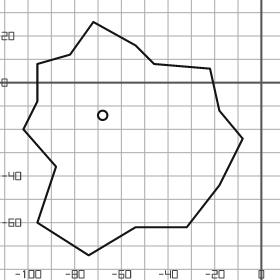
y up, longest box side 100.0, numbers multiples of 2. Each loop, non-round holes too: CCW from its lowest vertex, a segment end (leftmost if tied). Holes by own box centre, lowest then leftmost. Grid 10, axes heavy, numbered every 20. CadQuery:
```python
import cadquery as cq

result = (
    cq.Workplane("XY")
    .moveTo(-74.0, -74.0)
    .lineTo(-54.0, -62.0)
    .lineTo(-32.0, -62.0)
    .lineTo(-18.0, -44.0)
    .lineTo(-8.0, -24.0)
    .lineTo(-18.0, -12.0)
    .lineTo(-22.0, 6.0)
    .lineTo(-46.0, 8.0)
    .lineTo(-54.0, 16.0)
    .lineTo(-72.0, 26.0)
    .lineTo(-82.0, 12.0)
    .lineTo(-96.0, 8.0)
    .lineTo(-96.0, -8.0)
    .lineTo(-102.0, -20.0)
    .lineTo(-88.0, -36.0)
    .lineTo(-96.0, -60.0)
    .close()
    .moveTo(-68.0, -14.0)
    .circle(2.0)
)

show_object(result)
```